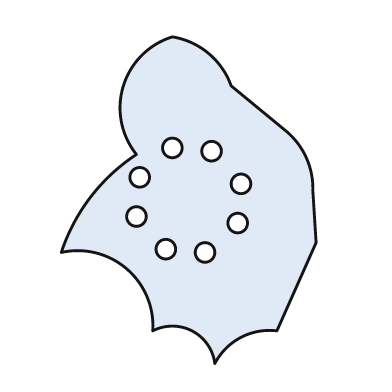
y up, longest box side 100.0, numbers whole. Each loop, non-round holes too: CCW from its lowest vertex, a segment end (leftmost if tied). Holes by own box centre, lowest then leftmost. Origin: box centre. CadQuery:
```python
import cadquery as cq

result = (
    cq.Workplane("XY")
    .moveTo(8.0, -50.0)
    .threePointArc((16.0, -42.0), (27.0, -40.0))
    .lineTo(39.0, -13.0)
    .lineTo(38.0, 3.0)
    .threePointArc((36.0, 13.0), (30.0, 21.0))
    .lineTo(13.0, 35.0)
    .threePointArc((6.0, 45.0), (-5.0, 50.0))
    .threePointArc((-20.0, 35.0), (-16.0, 14.0))
    .threePointArc((-30.0, 1.0), (-39.0, -16.0))
    .threePointArc((-19.0, -21.0), (-11.0, -40.0))
    .threePointArc((1.0, -40.0), (8.0, -50.0))
    .close()
    .moveTo(5.0, -16.0)
    .circle(3.0)
    .moveTo(-7.0, -15.0)
    .circle(3.0)
    .moveTo(15.0, -7.0)
    .circle(3.0)
    .moveTo(-16.0, -5.0)
    .circle(3.0)
    .moveTo(16.0, 5.0)
    .circle(3.0)
    .moveTo(-15.0, 7.0)
    .circle(3.0)
    .moveTo(7.0, 15.0)
    .circle(3.0)
    .moveTo(-5.0, 16.0)
    .circle(3.0)
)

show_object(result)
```